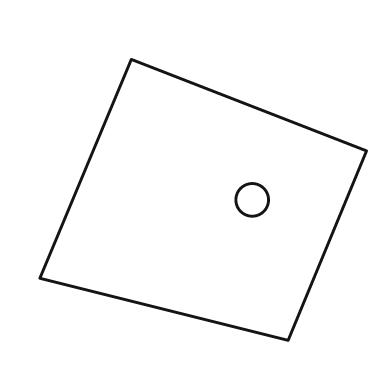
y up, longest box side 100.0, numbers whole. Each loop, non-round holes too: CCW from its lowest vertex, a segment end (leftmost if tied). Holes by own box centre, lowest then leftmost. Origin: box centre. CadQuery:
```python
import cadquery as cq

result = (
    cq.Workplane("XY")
    .moveTo(26.0, -43.0)
    .lineTo(50.0, 15.0)
    .lineTo(-22.0, 43.0)
    .lineTo(-50.0, -24.0)
    .close()
    .moveTo(15.0, 0.0)
    .circle(5.0)
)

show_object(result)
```